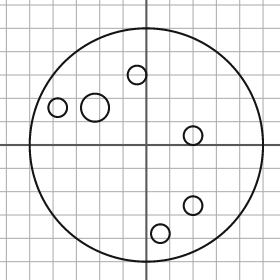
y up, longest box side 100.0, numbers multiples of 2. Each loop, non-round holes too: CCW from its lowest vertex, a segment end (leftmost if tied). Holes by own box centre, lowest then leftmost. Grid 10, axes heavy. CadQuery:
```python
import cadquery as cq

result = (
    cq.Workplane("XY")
    .moveTo(0.0, 0.0)
    .circle(50.0)
    .moveTo(6.0, -38.0)
    .circle(4.0)
    .moveTo(20.0, -26.0)
    .circle(4.0)
    .moveTo(20.0, 4.0)
    .circle(4.0)
    .moveTo(-38.0, 16.0)
    .circle(4.0)
    .moveTo(-22.0, 16.0)
    .circle(6.0)
    .moveTo(-4.0, 30.0)
    .circle(4.0)
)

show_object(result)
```